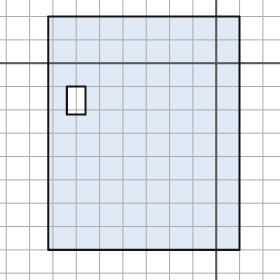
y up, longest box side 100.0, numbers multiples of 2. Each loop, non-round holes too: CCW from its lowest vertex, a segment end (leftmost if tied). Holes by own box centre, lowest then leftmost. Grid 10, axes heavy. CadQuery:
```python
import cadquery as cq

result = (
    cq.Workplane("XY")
    .moveTo(-72.0, -80.0)
    .lineTo(10.0, -80.0)
    .lineTo(10.0, 20.0)
    .lineTo(-72.0, 20.0)
    .close()
    .moveTo(-64.0, -22.0)
    .lineTo(-56.0, -22.0)
    .lineTo(-56.0, -10.0)
    .lineTo(-64.0, -10.0)
    .close()
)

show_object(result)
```